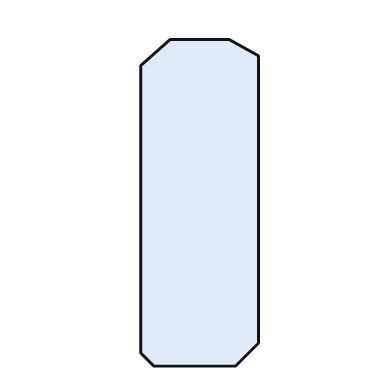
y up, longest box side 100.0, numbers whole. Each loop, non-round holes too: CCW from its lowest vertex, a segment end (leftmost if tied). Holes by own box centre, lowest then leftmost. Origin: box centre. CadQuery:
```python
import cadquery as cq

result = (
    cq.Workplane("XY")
    .moveTo(-14.0, -50.0)
    .lineTo(11.0, -50.0)
    .lineTo(18.0, -43.0)
    .lineTo(18.0, 45.0)
    .lineTo(9.0, 50.0)
    .lineTo(-9.0, 50.0)
    .lineTo(-18.0, 42.0)
    .lineTo(-18.0, -46.0)
    .close()
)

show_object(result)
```